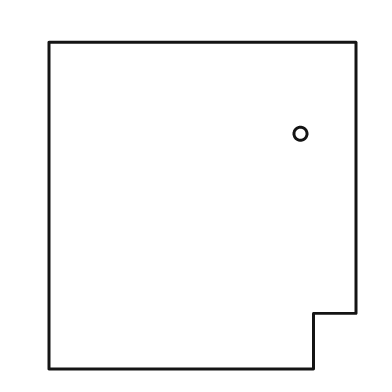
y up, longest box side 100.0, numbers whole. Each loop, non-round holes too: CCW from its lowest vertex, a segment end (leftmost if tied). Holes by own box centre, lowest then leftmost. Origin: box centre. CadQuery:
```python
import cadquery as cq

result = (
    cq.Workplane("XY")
    .moveTo(-47.0, -50.0)
    .lineTo(34.0, -50.0)
    .lineTo(34.0, -33.0)
    .lineTo(47.0, -33.0)
    .lineTo(47.0, 50.0)
    .lineTo(-47.0, 50.0)
    .close()
    .moveTo(30.0, 22.0)
    .circle(2.0)
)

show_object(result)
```